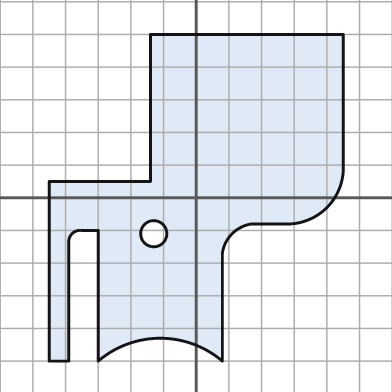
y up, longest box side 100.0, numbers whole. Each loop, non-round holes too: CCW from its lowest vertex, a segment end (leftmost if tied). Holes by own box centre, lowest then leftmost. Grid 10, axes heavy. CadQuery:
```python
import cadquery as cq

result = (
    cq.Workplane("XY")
    .moveTo(-45.0, -50.0)
    .lineTo(-39.0, -50.0)
    .lineTo(-39.0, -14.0)
    .threePointArc((-38.0, -11.0), (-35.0, -10.0))
    .lineTo(-30.0, -10.0)
    .lineTo(-30.0, -50.0)
    .threePointArc((-11.0, -43.0), (8.0, -50.0))
    .lineTo(8.0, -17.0)
    .threePointArc((11.0, -11.0), (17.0, -8.0))
    .lineTo(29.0, -8.0)
    .threePointArc((40.0, -3.0), (45.0, 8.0))
    .lineTo(45.0, 50.0)
    .lineTo(-14.0, 50.0)
    .lineTo(-14.0, 5.0)
    .lineTo(-45.0, 5.0)
    .close()
    .moveTo(-13.0, -11.0)
    .circle(4.0)
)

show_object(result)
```